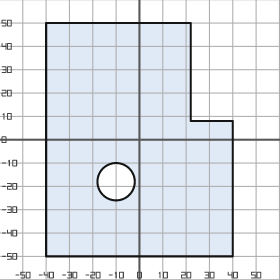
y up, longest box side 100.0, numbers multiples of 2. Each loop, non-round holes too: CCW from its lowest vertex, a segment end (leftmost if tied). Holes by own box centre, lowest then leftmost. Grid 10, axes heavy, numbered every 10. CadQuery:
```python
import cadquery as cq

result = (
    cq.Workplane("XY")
    .moveTo(-40.0, -50.0)
    .lineTo(40.0, -50.0)
    .lineTo(40.0, 8.0)
    .lineTo(22.0, 8.0)
    .lineTo(22.0, 50.0)
    .lineTo(-40.0, 50.0)
    .close()
    .moveTo(-10.0, -18.0)
    .circle(8.0)
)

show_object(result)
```